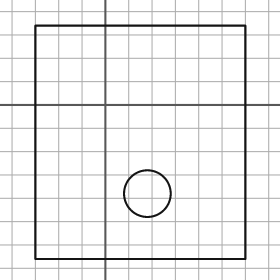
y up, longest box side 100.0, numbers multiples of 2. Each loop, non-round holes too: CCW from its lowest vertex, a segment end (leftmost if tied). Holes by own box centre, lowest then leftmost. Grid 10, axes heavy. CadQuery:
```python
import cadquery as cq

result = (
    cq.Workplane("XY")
    .moveTo(-30.0, -66.0)
    .lineTo(60.0, -66.0)
    .lineTo(60.0, 34.0)
    .lineTo(-30.0, 34.0)
    .close()
    .moveTo(18.0, -38.0)
    .circle(10.0)
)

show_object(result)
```